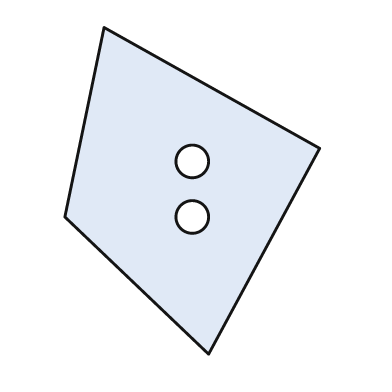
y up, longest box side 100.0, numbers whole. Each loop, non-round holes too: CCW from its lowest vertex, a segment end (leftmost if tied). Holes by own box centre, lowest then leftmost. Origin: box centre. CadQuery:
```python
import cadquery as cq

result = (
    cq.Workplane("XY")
    .moveTo(5.0, -50.0)
    .lineTo(39.0, 13.0)
    .lineTo(-27.0, 50.0)
    .lineTo(-39.0, -8.0)
    .close()
    .moveTo(0.0, -8.0)
    .circle(5.0)
    .moveTo(0.0, 9.0)
    .circle(5.0)
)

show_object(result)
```